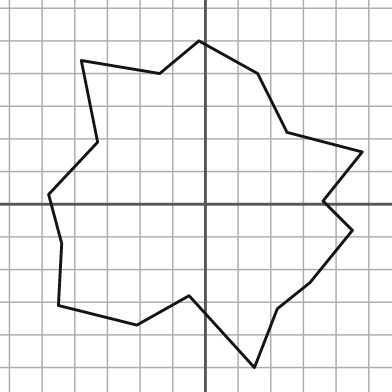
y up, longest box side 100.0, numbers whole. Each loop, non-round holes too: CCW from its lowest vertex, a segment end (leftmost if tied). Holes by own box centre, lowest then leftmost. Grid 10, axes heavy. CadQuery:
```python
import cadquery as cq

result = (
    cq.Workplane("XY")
    .moveTo(15.0, -50.0)
    .lineTo(22.0, -32.0)
    .lineTo(32.0, -24.0)
    .lineTo(45.0, -8.0)
    .lineTo(36.0, 1.0)
    .lineTo(48.0, 16.0)
    .lineTo(25.0, 22.0)
    .lineTo(16.0, 40.0)
    .lineTo(-2.0, 50.0)
    .lineTo(-14.0, 40.0)
    .lineTo(-38.0, 44.0)
    .lineTo(-33.0, 19.0)
    .lineTo(-48.0, 3.0)
    .lineTo(-44.0, -12.0)
    .lineTo(-45.0, -31.0)
    .lineTo(-21.0, -37.0)
    .lineTo(-5.0, -28.0)
    .close()
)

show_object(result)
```